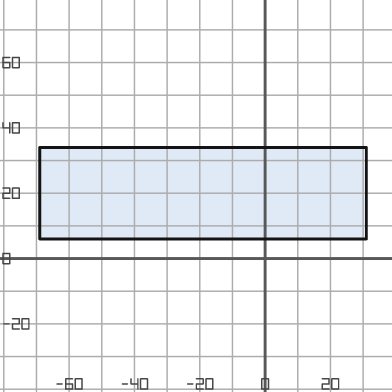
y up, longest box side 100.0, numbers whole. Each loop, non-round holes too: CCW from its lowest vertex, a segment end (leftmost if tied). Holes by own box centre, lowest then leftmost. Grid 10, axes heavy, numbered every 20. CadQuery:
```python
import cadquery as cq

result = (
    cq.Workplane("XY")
    .moveTo(-69.0, 6.0)
    .lineTo(31.0, 6.0)
    .lineTo(31.0, 34.0)
    .lineTo(-69.0, 34.0)
    .close()
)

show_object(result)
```